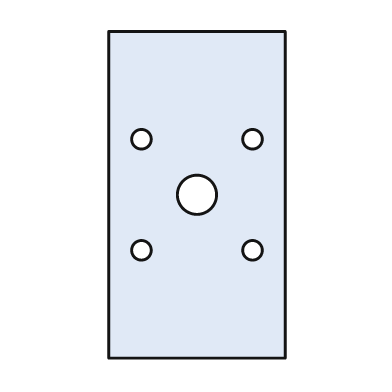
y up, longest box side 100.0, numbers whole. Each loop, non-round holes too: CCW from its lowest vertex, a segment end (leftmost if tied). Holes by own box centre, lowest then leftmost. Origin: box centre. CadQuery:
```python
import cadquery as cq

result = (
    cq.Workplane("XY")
    .moveTo(-27.0, -50.0)
    .lineTo(27.0, -50.0)
    .lineTo(27.0, 50.0)
    .lineTo(-27.0, 50.0)
    .close()
    .moveTo(-17.0, -17.0)
    .circle(3.0)
    .moveTo(17.0, -17.0)
    .circle(3.0)
    .moveTo(0.0, 0.0)
    .circle(6.0)
    .moveTo(-17.0, 17.0)
    .circle(3.0)
    .moveTo(17.0, 17.0)
    .circle(3.0)
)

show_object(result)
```